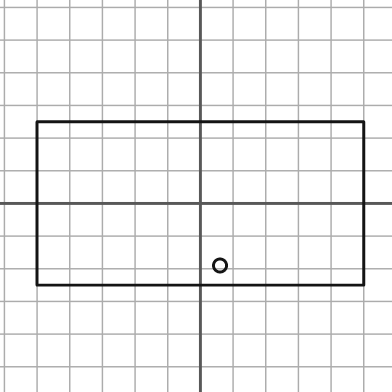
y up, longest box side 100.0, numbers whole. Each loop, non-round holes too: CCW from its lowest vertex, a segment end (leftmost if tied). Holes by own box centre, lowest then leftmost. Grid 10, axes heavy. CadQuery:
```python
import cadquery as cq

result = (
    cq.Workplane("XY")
    .moveTo(-50.0, -25.0)
    .lineTo(50.0, -25.0)
    .lineTo(50.0, 25.0)
    .lineTo(-50.0, 25.0)
    .close()
    .moveTo(6.0, -19.0)
    .circle(2.0)
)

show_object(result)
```